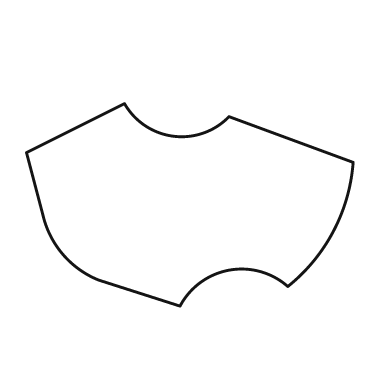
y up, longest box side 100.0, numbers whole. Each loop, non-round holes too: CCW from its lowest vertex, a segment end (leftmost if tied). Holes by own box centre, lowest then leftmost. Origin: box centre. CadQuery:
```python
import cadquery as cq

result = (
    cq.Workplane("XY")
    .moveTo(-3.0, -31.0)
    .threePointArc((12.0, -20.0), (30.0, -25.0))
    .threePointArc((44.0, -8.0), (50.0, 13.0))
    .lineTo(12.0, 27.0)
    .threePointArc((-5.0, 21.0), (-20.0, 31.0))
    .lineTo(-50.0, 16.0)
    .lineTo(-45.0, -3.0)
    .threePointArc((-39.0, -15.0), (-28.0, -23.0))
    .close()
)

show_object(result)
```